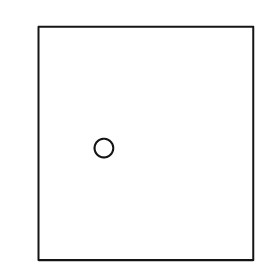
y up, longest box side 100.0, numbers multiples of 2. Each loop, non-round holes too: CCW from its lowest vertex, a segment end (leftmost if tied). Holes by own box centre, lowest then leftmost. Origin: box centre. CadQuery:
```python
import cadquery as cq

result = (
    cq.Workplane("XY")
    .moveTo(-46.0, -50.0)
    .lineTo(46.0, -50.0)
    .lineTo(46.0, 50.0)
    .lineTo(-46.0, 50.0)
    .close()
    .moveTo(-18.0, -2.0)
    .circle(4.0)
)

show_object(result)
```